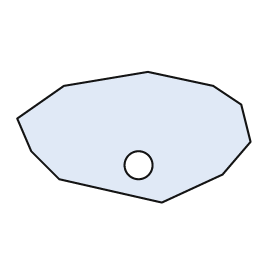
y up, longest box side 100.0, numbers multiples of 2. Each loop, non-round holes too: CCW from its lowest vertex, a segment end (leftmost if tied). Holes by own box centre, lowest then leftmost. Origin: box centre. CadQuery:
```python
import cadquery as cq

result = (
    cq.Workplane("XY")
    .moveTo(12.0, -28.0)
    .lineTo(38.0, -16.0)
    .lineTo(50.0, -2.0)
    .lineTo(46.0, 14.0)
    .lineTo(34.0, 22.0)
    .lineTo(6.0, 28.0)
    .lineTo(-30.0, 22.0)
    .lineTo(-50.0, 8.0)
    .lineTo(-44.0, -6.0)
    .lineTo(-32.0, -18.0)
    .close()
    .moveTo(2.0, -12.0)
    .circle(6.0)
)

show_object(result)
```